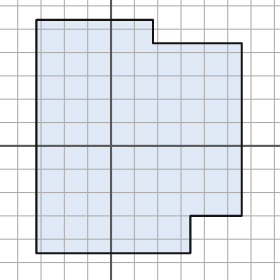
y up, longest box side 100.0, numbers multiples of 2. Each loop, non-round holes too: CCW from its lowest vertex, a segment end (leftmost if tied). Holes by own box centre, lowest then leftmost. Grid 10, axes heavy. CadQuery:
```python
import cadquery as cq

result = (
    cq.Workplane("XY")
    .moveTo(-32.0, -46.0)
    .lineTo(34.0, -46.0)
    .lineTo(34.0, -30.0)
    .lineTo(56.0, -30.0)
    .lineTo(56.0, 44.0)
    .lineTo(18.0, 44.0)
    .lineTo(18.0, 54.0)
    .lineTo(-32.0, 54.0)
    .close()
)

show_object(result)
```